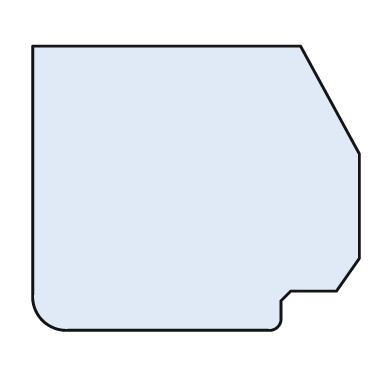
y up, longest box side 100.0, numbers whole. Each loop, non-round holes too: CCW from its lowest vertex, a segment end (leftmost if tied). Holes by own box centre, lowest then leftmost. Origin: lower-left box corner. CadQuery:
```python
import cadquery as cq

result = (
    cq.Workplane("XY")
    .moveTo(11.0, 0.0)
    .lineTo(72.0, 0.0)
    .threePointArc((75.0, 1.0), (76.0, 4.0))
    .lineTo(76.0, 9.0)
    .lineTo(79.0, 12.0)
    .lineTo(93.0, 12.0)
    .lineTo(100.0, 22.0)
    .lineTo(100.0, 54.0)
    .lineTo(82.0, 87.0)
    .lineTo(0.0, 87.0)
    .lineTo(0.0, 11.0)
    .threePointArc((3.0, 3.0), (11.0, 0.0))
    .close()
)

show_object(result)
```